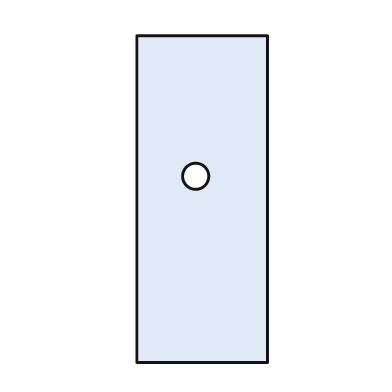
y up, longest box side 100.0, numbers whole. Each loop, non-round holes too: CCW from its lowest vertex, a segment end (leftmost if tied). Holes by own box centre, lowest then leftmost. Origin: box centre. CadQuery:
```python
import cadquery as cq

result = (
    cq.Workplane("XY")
    .moveTo(-20.0, -50.0)
    .lineTo(20.0, -50.0)
    .lineTo(20.0, 50.0)
    .lineTo(-20.0, 50.0)
    .close()
    .moveTo(-2.0, 7.0)
    .circle(4.0)
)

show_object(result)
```